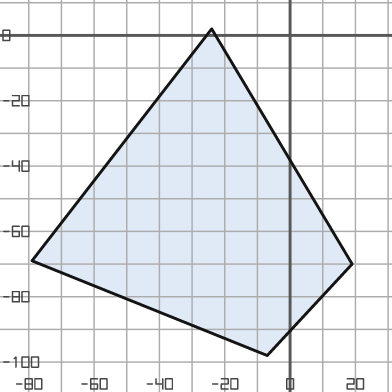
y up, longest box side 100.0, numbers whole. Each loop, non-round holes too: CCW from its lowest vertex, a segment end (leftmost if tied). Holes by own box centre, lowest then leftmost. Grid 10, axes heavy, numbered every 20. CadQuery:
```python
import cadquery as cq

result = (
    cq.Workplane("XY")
    .moveTo(-7.0, -98.0)
    .lineTo(19.0, -70.0)
    .lineTo(-24.0, 2.0)
    .lineTo(-79.0, -69.0)
    .close()
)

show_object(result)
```